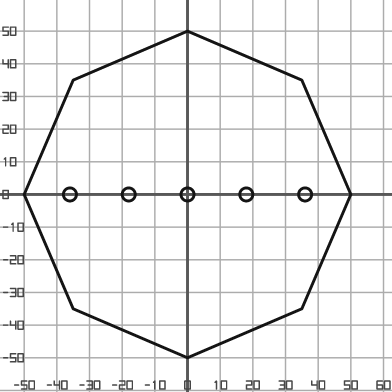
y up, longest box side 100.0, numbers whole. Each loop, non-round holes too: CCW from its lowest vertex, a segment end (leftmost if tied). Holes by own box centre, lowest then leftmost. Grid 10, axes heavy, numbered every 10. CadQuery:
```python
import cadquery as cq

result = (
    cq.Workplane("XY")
    .moveTo(0.0, -50.0)
    .lineTo(35.0, -35.0)
    .lineTo(50.0, 0.0)
    .lineTo(35.0, 35.0)
    .lineTo(0.0, 50.0)
    .lineTo(-35.0, 35.0)
    .lineTo(-50.0, 0.0)
    .lineTo(-35.0, -35.0)
    .close()
    .moveTo(-36.0, 0.0)
    .circle(2.0)
    .moveTo(-18.0, 0.0)
    .circle(2.0)
    .moveTo(0.0, 0.0)
    .circle(2.0)
    .moveTo(18.0, 0.0)
    .circle(2.0)
    .moveTo(36.0, 0.0)
    .circle(2.0)
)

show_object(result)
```